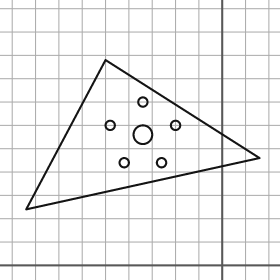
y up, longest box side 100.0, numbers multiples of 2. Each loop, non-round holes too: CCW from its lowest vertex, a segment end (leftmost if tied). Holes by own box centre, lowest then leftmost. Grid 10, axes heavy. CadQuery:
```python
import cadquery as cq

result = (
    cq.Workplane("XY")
    .moveTo(-84.0, 24.0)
    .lineTo(16.0, 46.0)
    .lineTo(-50.0, 88.0)
    .close()
    .moveTo(-42.0, 44.0)
    .circle(2.0)
    .moveTo(-26.0, 44.0)
    .circle(2.0)
    .moveTo(-34.0, 56.0)
    .circle(4.0)
    .moveTo(-48.0, 60.0)
    .circle(2.0)
    .moveTo(-20.0, 60.0)
    .circle(2.0)
    .moveTo(-34.0, 70.0)
    .circle(2.0)
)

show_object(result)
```